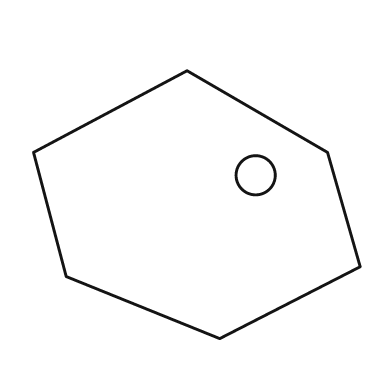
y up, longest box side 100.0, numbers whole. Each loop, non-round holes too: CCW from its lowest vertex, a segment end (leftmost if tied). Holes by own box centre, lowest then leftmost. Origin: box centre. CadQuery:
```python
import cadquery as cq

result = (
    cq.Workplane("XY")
    .moveTo(7.0, -41.0)
    .lineTo(50.0, -19.0)
    .lineTo(40.0, 16.0)
    .lineTo(-3.0, 41.0)
    .lineTo(-50.0, 16.0)
    .lineTo(-40.0, -22.0)
    .close()
    .moveTo(18.0, 9.0)
    .circle(6.0)
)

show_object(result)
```